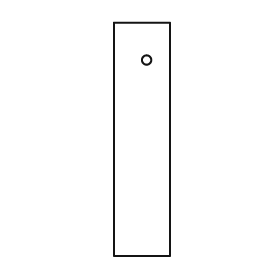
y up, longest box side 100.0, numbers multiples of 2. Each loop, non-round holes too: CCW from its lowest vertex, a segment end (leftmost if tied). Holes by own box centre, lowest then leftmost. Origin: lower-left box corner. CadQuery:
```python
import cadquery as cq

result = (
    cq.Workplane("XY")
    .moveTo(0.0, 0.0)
    .lineTo(24.0, 0.0)
    .lineTo(24.0, 100.0)
    .lineTo(0.0, 100.0)
    .close()
    .moveTo(14.0, 84.0)
    .circle(2.0)
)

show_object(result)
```